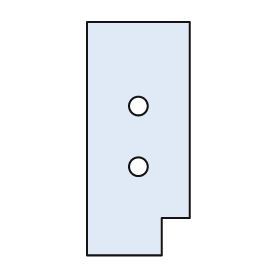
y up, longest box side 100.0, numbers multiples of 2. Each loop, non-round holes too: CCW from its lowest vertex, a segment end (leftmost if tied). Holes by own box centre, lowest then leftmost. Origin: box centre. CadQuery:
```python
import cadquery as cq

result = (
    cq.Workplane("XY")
    .moveTo(-22.0, -50.0)
    .lineTo(10.0, -50.0)
    .lineTo(10.0, -34.0)
    .lineTo(22.0, -34.0)
    .lineTo(22.0, 50.0)
    .lineTo(-22.0, 50.0)
    .close()
    .moveTo(0.0, -12.0)
    .circle(4.0)
    .moveTo(0.0, 14.0)
    .circle(4.0)
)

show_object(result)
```